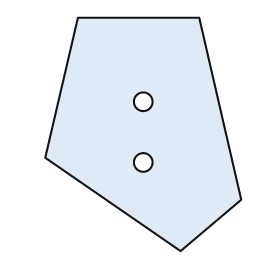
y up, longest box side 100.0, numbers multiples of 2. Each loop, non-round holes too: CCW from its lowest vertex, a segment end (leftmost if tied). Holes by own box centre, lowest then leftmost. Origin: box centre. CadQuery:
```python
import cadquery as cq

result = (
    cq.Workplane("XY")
    .moveTo(16.0, -50.0)
    .lineTo(42.0, -28.0)
    .lineTo(24.0, 50.0)
    .lineTo(-28.0, 50.0)
    .lineTo(-42.0, -10.0)
    .close()
    .moveTo(0.0, -12.0)
    .circle(4.0)
    .moveTo(0.0, 14.0)
    .circle(4.0)
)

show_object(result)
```